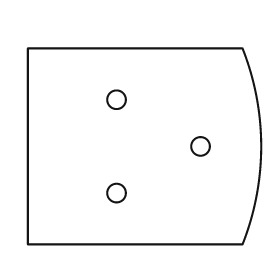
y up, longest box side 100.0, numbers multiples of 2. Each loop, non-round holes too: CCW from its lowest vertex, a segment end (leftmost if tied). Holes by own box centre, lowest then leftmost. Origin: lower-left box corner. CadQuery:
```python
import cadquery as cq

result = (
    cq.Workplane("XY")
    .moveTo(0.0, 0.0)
    .lineTo(92.0, 0.0)
    .threePointArc((100.0, 42.0), (92.0, 84.0))
    .lineTo(0.0, 84.0)
    .close()
    .moveTo(38.0, 22.0)
    .circle(4.0)
    .moveTo(74.0, 42.0)
    .circle(4.0)
    .moveTo(38.0, 62.0)
    .circle(4.0)
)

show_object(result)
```